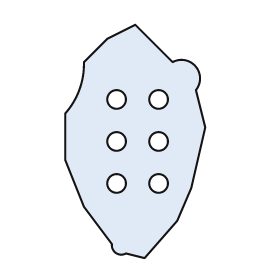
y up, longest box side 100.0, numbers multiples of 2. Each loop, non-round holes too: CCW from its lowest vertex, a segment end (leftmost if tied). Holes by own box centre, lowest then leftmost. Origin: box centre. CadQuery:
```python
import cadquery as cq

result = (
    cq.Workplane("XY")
    .moveTo(4.0, -50.0)
    .lineTo(18.0, -34.0)
    .lineTo(24.0, -20.0)
    .lineTo(30.0, 6.0)
    .lineTo(26.0, 22.0)
    .threePointArc((26.0, 32.0), (16.0, 34.0))
    .lineTo(0.0, 50.0)
    .lineTo(-12.0, 44.0)
    .lineTo(-22.0, 34.0)
    .threePointArc((-24.0, 22.0), (-30.0, 12.0))
    .lineTo(-30.0, -8.0)
    .lineTo(-22.0, -28.0)
    .lineTo(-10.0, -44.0)
    .threePointArc((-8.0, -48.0), (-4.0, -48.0))
    .close()
    .moveTo(-8.0, -18.0)
    .circle(4.0)
    .moveTo(10.0, -18.0)
    .circle(4.0)
    .moveTo(-8.0, 0.0)
    .circle(4.0)
    .moveTo(10.0, 0.0)
    .circle(4.0)
    .moveTo(-8.0, 18.0)
    .circle(4.0)
    .moveTo(10.0, 18.0)
    .circle(4.0)
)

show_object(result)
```